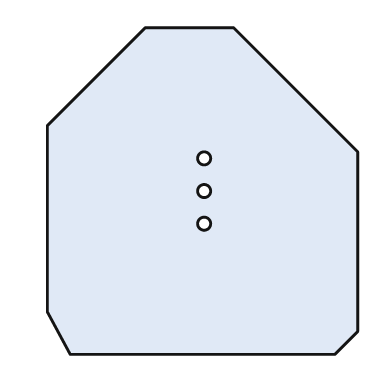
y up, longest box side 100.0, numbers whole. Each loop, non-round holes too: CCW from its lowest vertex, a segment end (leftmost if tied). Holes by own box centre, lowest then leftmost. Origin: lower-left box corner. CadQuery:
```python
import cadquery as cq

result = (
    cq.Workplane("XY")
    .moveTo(7.0, 0.0)
    .lineTo(88.0, 0.0)
    .lineTo(95.0, 7.0)
    .lineTo(95.0, 62.0)
    .lineTo(57.0, 100.0)
    .lineTo(30.0, 100.0)
    .lineTo(0.0, 70.0)
    .lineTo(0.0, 13.0)
    .close()
    .moveTo(48.0, 40.0)
    .circle(2.0)
    .moveTo(48.0, 50.0)
    .circle(2.0)
    .moveTo(48.0, 60.0)
    .circle(2.0)
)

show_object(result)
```